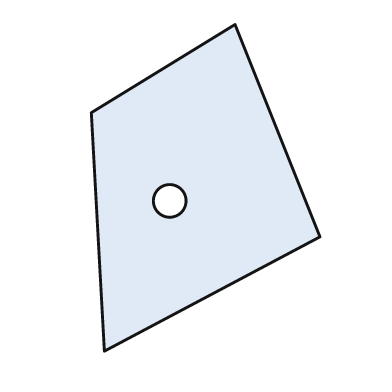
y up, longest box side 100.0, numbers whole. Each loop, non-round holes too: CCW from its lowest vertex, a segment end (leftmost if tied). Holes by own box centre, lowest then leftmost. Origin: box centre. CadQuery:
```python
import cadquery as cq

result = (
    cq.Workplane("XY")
    .moveTo(-31.0, -50.0)
    .lineTo(35.0, -15.0)
    .lineTo(9.0, 50.0)
    .lineTo(-35.0, 23.0)
    .close()
    .moveTo(-11.0, -4.0)
    .circle(5.0)
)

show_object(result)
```